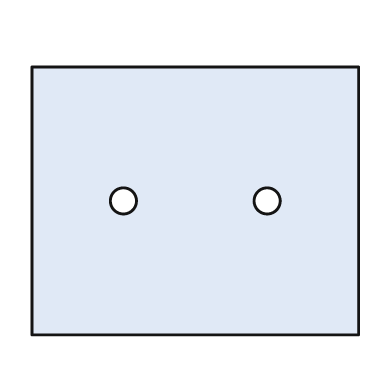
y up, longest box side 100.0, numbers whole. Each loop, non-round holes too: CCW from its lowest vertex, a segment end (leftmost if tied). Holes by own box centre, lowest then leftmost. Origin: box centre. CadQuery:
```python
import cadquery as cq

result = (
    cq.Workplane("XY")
    .moveTo(-50.0, -41.0)
    .lineTo(50.0, -41.0)
    .lineTo(50.0, 41.0)
    .lineTo(-50.0, 41.0)
    .close()
    .moveTo(-22.0, 0.0)
    .circle(4.0)
    .moveTo(22.0, 0.0)
    .circle(4.0)
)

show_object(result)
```